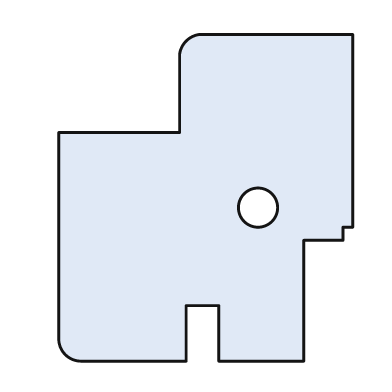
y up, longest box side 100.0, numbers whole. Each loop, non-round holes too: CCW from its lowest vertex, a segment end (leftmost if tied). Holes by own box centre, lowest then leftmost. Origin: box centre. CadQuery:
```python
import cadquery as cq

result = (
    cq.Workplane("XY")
    .moveTo(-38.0, -50.0)
    .lineTo(-6.0, -50.0)
    .lineTo(-6.0, -33.0)
    .lineTo(4.0, -33.0)
    .lineTo(4.0, -50.0)
    .lineTo(30.0, -50.0)
    .lineTo(30.0, -13.0)
    .lineTo(42.0, -13.0)
    .lineTo(42.0, -9.0)
    .lineTo(45.0, -9.0)
    .lineTo(45.0, 50.0)
    .lineTo(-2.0, 50.0)
    .threePointArc((-6.0, 48.0), (-8.0, 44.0))
    .lineTo(-8.0, 20.0)
    .lineTo(-45.0, 20.0)
    .lineTo(-45.0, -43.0)
    .threePointArc((-43.0, -48.0), (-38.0, -50.0))
    .close()
    .moveTo(16.0, -3.0)
    .circle(6.0)
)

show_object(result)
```